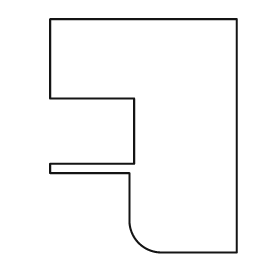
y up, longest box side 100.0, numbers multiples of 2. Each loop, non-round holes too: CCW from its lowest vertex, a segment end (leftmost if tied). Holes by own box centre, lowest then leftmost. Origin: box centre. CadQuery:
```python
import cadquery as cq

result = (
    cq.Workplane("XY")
    .moveTo(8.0, -50.0)
    .lineTo(40.0, -50.0)
    .lineTo(40.0, 50.0)
    .lineTo(-40.0, 50.0)
    .lineTo(-40.0, 16.0)
    .lineTo(-4.0, 16.0)
    .lineTo(-4.0, -12.0)
    .lineTo(-40.0, -12.0)
    .lineTo(-40.0, -16.0)
    .lineTo(-6.0, -16.0)
    .lineTo(-6.0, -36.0)
    .threePointArc((-2.0, -46.0), (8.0, -50.0))
    .close()
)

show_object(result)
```